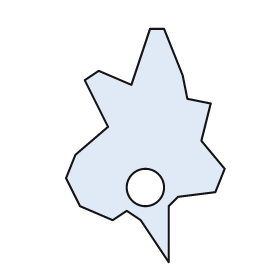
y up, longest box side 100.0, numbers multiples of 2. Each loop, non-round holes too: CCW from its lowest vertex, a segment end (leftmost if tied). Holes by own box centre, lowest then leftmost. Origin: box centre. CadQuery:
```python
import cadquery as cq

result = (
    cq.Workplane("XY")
    .moveTo(10.0, -50.0)
    .lineTo(10.0, -26.0)
    .lineTo(14.0, -22.0)
    .lineTo(30.0, -20.0)
    .lineTo(34.0, -10.0)
    .lineTo(24.0, 2.0)
    .lineTo(28.0, 18.0)
    .lineTo(18.0, 20.0)
    .lineTo(16.0, 30.0)
    .lineTo(8.0, 50.0)
    .lineTo(2.0, 50.0)
    .lineTo(-6.0, 26.0)
    .lineTo(-20.0, 32.0)
    .lineTo(-26.0, 28.0)
    .lineTo(-16.0, 8.0)
    .lineTo(-30.0, -4.0)
    .lineTo(-34.0, -14.0)
    .lineTo(-28.0, -26.0)
    .lineTo(-14.0, -32.0)
    .lineTo(-8.0, -28.0)
    .lineTo(-2.0, -32.0)
    .close()
    .moveTo(0.0, -18.0)
    .circle(8.0)
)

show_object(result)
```